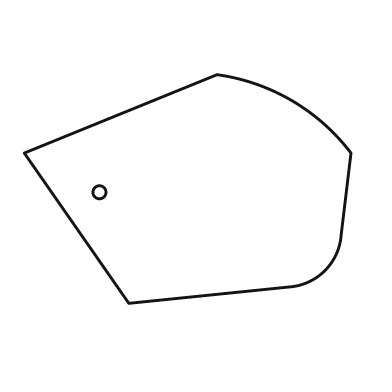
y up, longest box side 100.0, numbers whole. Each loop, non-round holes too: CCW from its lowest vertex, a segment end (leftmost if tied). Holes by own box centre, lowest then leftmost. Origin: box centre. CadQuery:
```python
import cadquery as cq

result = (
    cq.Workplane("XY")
    .moveTo(-18.0, -35.0)
    .lineTo(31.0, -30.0)
    .threePointArc((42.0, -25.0), (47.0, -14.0))
    .lineTo(50.0, 11.0)
    .threePointArc((32.0, 27.0), (9.0, 35.0))
    .lineTo(-50.0, 11.0)
    .close()
    .moveTo(-27.0, -1.0)
    .circle(2.0)
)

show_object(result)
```